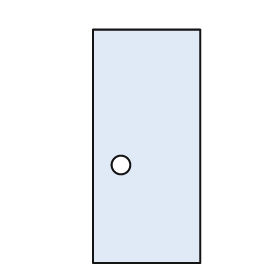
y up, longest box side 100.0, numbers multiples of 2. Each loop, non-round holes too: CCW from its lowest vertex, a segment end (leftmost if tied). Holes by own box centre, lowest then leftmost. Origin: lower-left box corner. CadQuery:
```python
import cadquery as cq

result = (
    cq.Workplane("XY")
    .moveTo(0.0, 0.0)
    .lineTo(46.0, 0.0)
    .lineTo(46.0, 100.0)
    .lineTo(0.0, 100.0)
    .close()
    .moveTo(12.0, 42.0)
    .circle(4.0)
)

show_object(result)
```